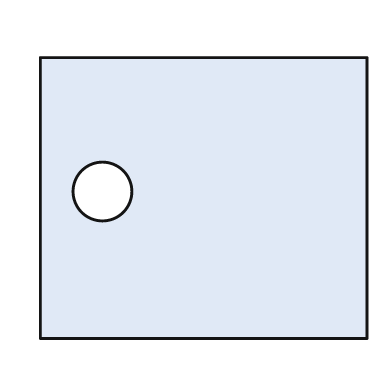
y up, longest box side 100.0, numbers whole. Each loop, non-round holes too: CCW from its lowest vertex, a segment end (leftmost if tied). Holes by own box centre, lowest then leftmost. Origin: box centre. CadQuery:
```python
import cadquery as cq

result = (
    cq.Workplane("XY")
    .moveTo(-50.0, -43.0)
    .lineTo(50.0, -43.0)
    .lineTo(50.0, 43.0)
    .lineTo(-50.0, 43.0)
    .close()
    .moveTo(-31.0, 2.0)
    .circle(9.0)
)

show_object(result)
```